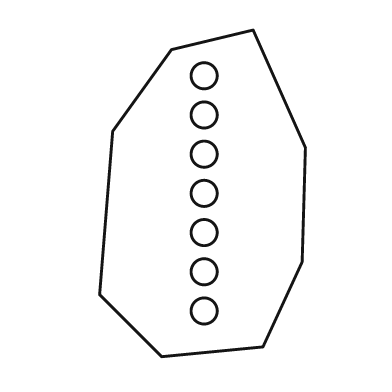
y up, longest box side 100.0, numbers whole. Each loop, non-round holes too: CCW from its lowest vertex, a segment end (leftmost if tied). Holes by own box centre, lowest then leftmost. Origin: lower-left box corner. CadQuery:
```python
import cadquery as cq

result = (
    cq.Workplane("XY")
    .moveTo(19.0, 0.0)
    .lineTo(50.0, 3.0)
    .lineTo(62.0, 29.0)
    .lineTo(63.0, 64.0)
    .lineTo(47.0, 100.0)
    .lineTo(22.0, 94.0)
    .lineTo(4.0, 69.0)
    .lineTo(0.0, 19.0)
    .close()
    .moveTo(32.0, 14.0)
    .circle(4.0)
    .moveTo(32.0, 26.0)
    .circle(4.0)
    .moveTo(32.0, 38.0)
    .circle(4.0)
    .moveTo(32.0, 50.0)
    .circle(4.0)
    .moveTo(32.0, 62.0)
    .circle(4.0)
    .moveTo(32.0, 74.0)
    .circle(4.0)
    .moveTo(32.0, 86.0)
    .circle(4.0)
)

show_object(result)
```